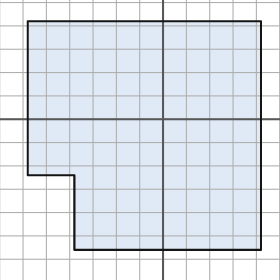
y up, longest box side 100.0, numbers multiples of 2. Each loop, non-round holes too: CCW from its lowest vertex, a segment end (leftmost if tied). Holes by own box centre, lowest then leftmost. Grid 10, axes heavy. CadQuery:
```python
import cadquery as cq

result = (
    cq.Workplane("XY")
    .moveTo(-38.0, -56.0)
    .lineTo(42.0, -56.0)
    .lineTo(42.0, 42.0)
    .lineTo(-58.0, 42.0)
    .lineTo(-58.0, -24.0)
    .lineTo(-38.0, -24.0)
    .close()
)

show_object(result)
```